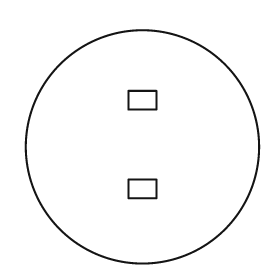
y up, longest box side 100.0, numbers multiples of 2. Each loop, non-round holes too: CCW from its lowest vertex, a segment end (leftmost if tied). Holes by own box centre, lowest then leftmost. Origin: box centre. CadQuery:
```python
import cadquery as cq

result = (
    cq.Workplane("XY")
    .moveTo(0.0, 0.0)
    .circle(50.0)
    .moveTo(-6.0, -22.0)
    .lineTo(6.0, -22.0)
    .lineTo(6.0, -14.0)
    .lineTo(-6.0, -14.0)
    .close()
    .moveTo(-6.0, 16.0)
    .lineTo(6.0, 16.0)
    .lineTo(6.0, 24.0)
    .lineTo(-6.0, 24.0)
    .close()
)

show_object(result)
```